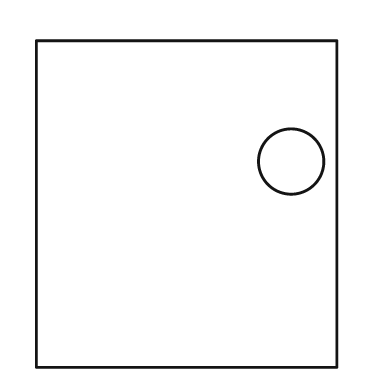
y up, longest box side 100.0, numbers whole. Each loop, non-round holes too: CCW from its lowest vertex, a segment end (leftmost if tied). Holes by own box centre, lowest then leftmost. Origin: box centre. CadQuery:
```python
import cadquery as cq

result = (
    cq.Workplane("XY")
    .moveTo(-46.0, -50.0)
    .lineTo(46.0, -50.0)
    .lineTo(46.0, 50.0)
    .lineTo(-46.0, 50.0)
    .close()
    .moveTo(32.0, 13.0)
    .circle(10.0)
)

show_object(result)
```